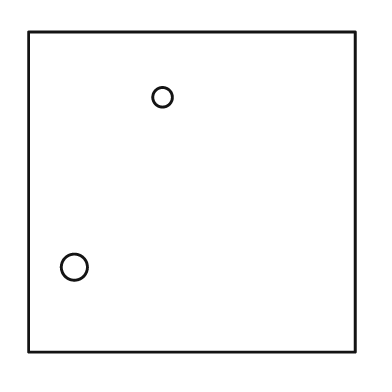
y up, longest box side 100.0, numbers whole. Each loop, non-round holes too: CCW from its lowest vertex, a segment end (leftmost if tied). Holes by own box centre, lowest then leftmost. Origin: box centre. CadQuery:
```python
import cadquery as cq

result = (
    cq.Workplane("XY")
    .moveTo(-50.0, -49.0)
    .lineTo(50.0, -49.0)
    .lineTo(50.0, 49.0)
    .lineTo(-50.0, 49.0)
    .close()
    .moveTo(-36.0, -23.0)
    .circle(4.0)
    .moveTo(-9.0, 29.0)
    .circle(3.0)
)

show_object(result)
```